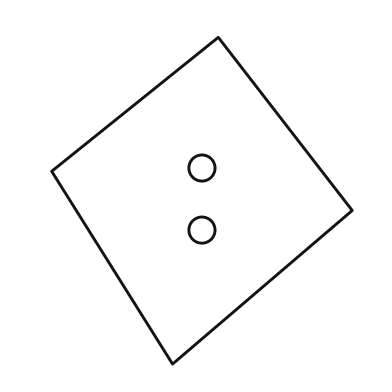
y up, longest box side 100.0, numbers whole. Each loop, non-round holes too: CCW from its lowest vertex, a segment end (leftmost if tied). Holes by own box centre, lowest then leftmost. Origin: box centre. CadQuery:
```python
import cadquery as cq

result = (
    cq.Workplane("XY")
    .moveTo(-9.0, -50.0)
    .lineTo(46.0, -3.0)
    .lineTo(5.0, 50.0)
    .lineTo(-46.0, 9.0)
    .close()
    .moveTo(0.0, -9.0)
    .circle(4.0)
    .moveTo(0.0, 10.0)
    .circle(4.0)
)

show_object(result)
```